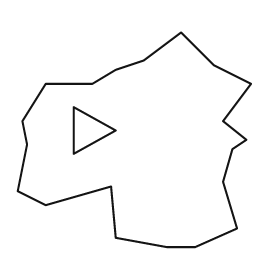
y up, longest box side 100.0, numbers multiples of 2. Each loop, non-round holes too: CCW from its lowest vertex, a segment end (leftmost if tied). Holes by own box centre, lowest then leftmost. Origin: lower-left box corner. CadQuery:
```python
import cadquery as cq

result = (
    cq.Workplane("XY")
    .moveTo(64.0, 0.0)
    .lineTo(76.0, 0.0)
    .lineTo(94.0, 8.0)
    .lineTo(88.0, 28.0)
    .lineTo(92.0, 42.0)
    .lineTo(98.0, 46.0)
    .lineTo(88.0, 54.0)
    .lineTo(100.0, 70.0)
    .lineTo(84.0, 78.0)
    .lineTo(70.0, 92.0)
    .lineTo(54.0, 80.0)
    .lineTo(42.0, 76.0)
    .lineTo(32.0, 70.0)
    .lineTo(12.0, 70.0)
    .lineTo(2.0, 54.0)
    .lineTo(4.0, 44.0)
    .lineTo(0.0, 24.0)
    .lineTo(12.0, 18.0)
    .lineTo(40.0, 26.0)
    .lineTo(42.0, 4.0)
    .close()
    .moveTo(24.0, 40.0)
    .lineTo(42.0, 50.0)
    .lineTo(24.0, 60.0)
    .close()
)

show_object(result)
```